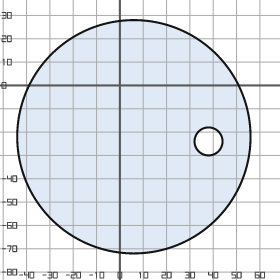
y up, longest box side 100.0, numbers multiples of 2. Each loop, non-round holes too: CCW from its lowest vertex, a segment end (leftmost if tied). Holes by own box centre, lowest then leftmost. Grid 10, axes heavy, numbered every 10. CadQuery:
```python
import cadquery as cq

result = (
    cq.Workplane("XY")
    .moveTo(6.0, -22.0)
    .circle(50.0)
    .moveTo(38.0, -24.0)
    .circle(6.0)
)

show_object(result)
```